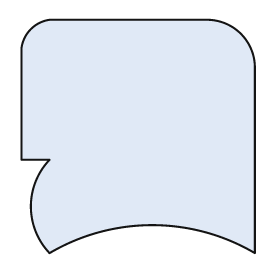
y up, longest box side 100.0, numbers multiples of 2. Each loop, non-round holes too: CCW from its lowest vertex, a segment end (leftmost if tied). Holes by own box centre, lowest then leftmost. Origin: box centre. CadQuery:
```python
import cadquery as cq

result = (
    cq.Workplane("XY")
    .moveTo(-38.0, -50.0)
    .threePointArc((6.0, -38.0), (50.0, -50.0))
    .lineTo(50.0, 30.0)
    .threePointArc((44.0, 44.0), (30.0, 50.0))
    .lineTo(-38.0, 50.0)
    .threePointArc((-46.0, 46.0), (-50.0, 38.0))
    .lineTo(-50.0, -10.0)
    .lineTo(-38.0, -10.0)
    .threePointArc((-46.0, -30.0), (-38.0, -50.0))
    .close()
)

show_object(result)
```